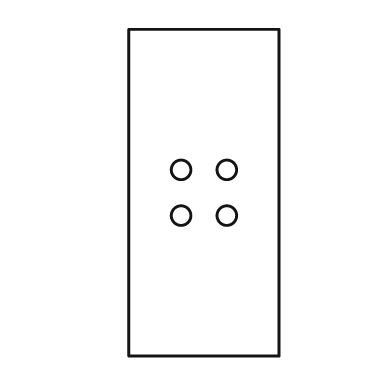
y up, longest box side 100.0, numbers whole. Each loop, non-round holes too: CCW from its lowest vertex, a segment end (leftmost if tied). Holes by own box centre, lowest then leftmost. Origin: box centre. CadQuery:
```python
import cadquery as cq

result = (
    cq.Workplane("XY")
    .moveTo(-23.0, -50.0)
    .lineTo(23.0, -50.0)
    .lineTo(23.0, 50.0)
    .lineTo(-23.0, 50.0)
    .close()
    .moveTo(-7.0, -7.0)
    .circle(3.0)
    .moveTo(7.0, -7.0)
    .circle(3.0)
    .moveTo(-7.0, 7.0)
    .circle(3.0)
    .moveTo(7.0, 7.0)
    .circle(3.0)
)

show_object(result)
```